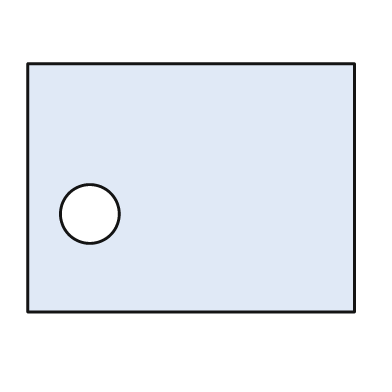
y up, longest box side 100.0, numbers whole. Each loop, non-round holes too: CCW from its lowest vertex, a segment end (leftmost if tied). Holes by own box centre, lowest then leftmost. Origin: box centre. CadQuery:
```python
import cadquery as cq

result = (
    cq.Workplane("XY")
    .moveTo(-50.0, -38.0)
    .lineTo(50.0, -38.0)
    .lineTo(50.0, 38.0)
    .lineTo(-50.0, 38.0)
    .close()
    .moveTo(-31.0, -8.0)
    .circle(9.0)
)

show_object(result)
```